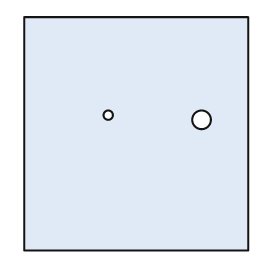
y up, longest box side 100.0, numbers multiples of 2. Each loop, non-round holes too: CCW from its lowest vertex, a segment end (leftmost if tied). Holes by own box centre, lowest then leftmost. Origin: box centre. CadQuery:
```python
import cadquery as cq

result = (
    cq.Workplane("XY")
    .moveTo(-48.0, -50.0)
    .lineTo(48.0, -50.0)
    .lineTo(48.0, 50.0)
    .lineTo(-48.0, 50.0)
    .close()
    .moveTo(28.0, 6.0)
    .circle(4.0)
    .moveTo(-12.0, 8.0)
    .circle(2.0)
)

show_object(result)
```